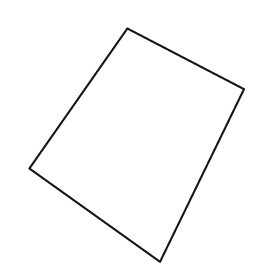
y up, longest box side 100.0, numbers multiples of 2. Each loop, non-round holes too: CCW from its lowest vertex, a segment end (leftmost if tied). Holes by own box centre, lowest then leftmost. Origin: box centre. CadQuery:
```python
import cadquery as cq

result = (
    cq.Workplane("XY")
    .moveTo(10.0, -50.0)
    .lineTo(46.0, 24.0)
    .lineTo(-4.0, 50.0)
    .lineTo(-46.0, -10.0)
    .close()
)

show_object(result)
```